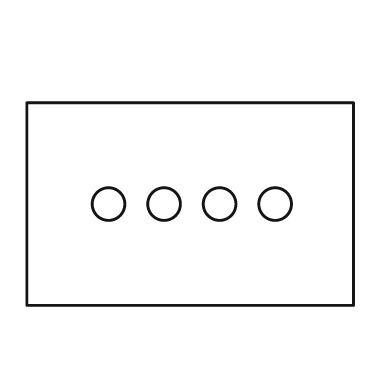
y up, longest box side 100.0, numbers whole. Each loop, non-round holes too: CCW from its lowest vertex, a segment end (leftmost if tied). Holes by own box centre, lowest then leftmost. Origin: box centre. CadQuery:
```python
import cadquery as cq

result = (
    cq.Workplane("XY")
    .moveTo(-50.0, -31.0)
    .lineTo(50.0, -31.0)
    .lineTo(50.0, 31.0)
    .lineTo(-50.0, 31.0)
    .close()
    .moveTo(-25.0, 0.0)
    .circle(5.0)
    .moveTo(-8.0, 0.0)
    .circle(5.0)
    .moveTo(9.0, 0.0)
    .circle(5.0)
    .moveTo(26.0, 0.0)
    .circle(5.0)
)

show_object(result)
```